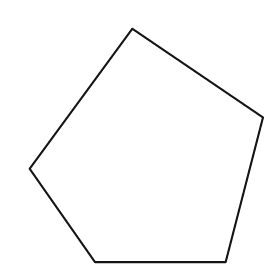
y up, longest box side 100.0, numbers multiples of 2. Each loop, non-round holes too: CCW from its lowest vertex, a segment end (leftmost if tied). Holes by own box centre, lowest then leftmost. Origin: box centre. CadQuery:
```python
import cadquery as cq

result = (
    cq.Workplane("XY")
    .moveTo(-22.0, -50.0)
    .lineTo(34.0, -50.0)
    .lineTo(50.0, 12.0)
    .lineTo(-6.0, 50.0)
    .lineTo(-50.0, -10.0)
    .close()
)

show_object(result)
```